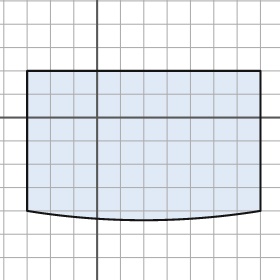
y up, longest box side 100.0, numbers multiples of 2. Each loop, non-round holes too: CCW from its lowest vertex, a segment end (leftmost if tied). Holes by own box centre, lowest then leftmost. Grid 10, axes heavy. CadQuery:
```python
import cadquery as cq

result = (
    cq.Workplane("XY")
    .moveTo(-30.0, -40.0)
    .threePointArc((20.0, -44.0), (70.0, -40.0))
    .lineTo(70.0, 20.0)
    .lineTo(-30.0, 20.0)
    .close()
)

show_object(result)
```